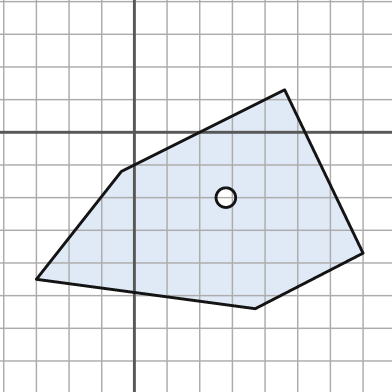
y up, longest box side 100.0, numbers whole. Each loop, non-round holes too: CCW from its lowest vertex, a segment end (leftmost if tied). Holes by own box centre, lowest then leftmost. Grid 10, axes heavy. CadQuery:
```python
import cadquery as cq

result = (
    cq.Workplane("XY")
    .moveTo(37.0, -54.0)
    .lineTo(70.0, -37.0)
    .lineTo(46.0, 13.0)
    .lineTo(-4.0, -12.0)
    .lineTo(-30.0, -45.0)
    .close()
    .moveTo(28.0, -20.0)
    .circle(3.0)
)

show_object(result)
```